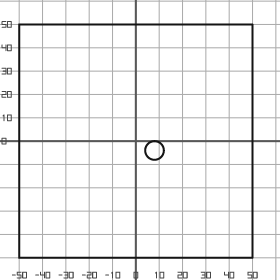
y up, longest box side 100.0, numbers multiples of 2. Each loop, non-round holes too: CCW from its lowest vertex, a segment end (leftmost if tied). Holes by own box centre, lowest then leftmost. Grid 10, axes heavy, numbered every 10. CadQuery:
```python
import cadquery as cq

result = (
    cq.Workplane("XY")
    .moveTo(-50.0, -50.0)
    .lineTo(50.0, -50.0)
    .lineTo(50.0, 50.0)
    .lineTo(-50.0, 50.0)
    .close()
    .moveTo(8.0, -4.0)
    .circle(4.0)
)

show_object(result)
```